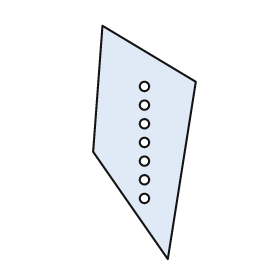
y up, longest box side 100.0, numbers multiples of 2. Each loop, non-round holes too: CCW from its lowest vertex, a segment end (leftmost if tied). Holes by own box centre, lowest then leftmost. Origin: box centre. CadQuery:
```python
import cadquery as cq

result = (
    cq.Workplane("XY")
    .moveTo(10.0, -50.0)
    .lineTo(22.0, 26.0)
    .lineTo(-18.0, 50.0)
    .lineTo(-22.0, -4.0)
    .close()
    .moveTo(0.0, -24.0)
    .circle(2.0)
    .moveTo(0.0, -16.0)
    .circle(2.0)
    .moveTo(0.0, -8.0)
    .circle(2.0)
    .moveTo(0.0, 0.0)
    .circle(2.0)
    .moveTo(0.0, 8.0)
    .circle(2.0)
    .moveTo(0.0, 16.0)
    .circle(2.0)
    .moveTo(0.0, 24.0)
    .circle(2.0)
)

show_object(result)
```